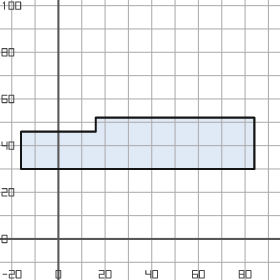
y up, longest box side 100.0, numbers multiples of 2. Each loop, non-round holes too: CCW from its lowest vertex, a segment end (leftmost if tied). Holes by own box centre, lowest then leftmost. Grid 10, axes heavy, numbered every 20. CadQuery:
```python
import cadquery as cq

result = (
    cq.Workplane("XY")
    .moveTo(-16.0, 30.0)
    .lineTo(84.0, 30.0)
    .lineTo(84.0, 52.0)
    .lineTo(16.0, 52.0)
    .lineTo(16.0, 46.0)
    .lineTo(-16.0, 46.0)
    .close()
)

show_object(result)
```